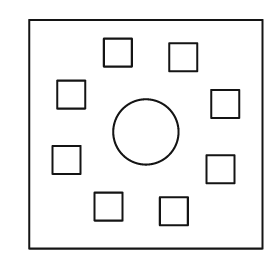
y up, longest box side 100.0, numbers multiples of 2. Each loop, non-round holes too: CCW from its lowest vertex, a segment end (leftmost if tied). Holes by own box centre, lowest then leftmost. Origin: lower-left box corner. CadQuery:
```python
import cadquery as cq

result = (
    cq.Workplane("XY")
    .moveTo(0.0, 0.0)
    .lineTo(100.0, 0.0)
    .lineTo(100.0, 98.0)
    .lineTo(0.0, 98.0)
    .close()
    .moveTo(56.0, 10.0)
    .lineTo(68.0, 10.0)
    .lineTo(68.0, 22.0)
    .lineTo(56.0, 22.0)
    .close()
    .moveTo(28.0, 12.0)
    .lineTo(40.0, 12.0)
    .lineTo(40.0, 24.0)
    .lineTo(28.0, 24.0)
    .close()
    .moveTo(76.0, 28.0)
    .lineTo(88.0, 28.0)
    .lineTo(88.0, 40.0)
    .lineTo(76.0, 40.0)
    .close()
    .moveTo(10.0, 32.0)
    .lineTo(22.0, 32.0)
    .lineTo(22.0, 44.0)
    .lineTo(10.0, 44.0)
    .close()
    .moveTo(50.0, 50.0)
    .circle(14.0)
    .moveTo(78.0, 56.0)
    .lineTo(90.0, 56.0)
    .lineTo(90.0, 68.0)
    .lineTo(78.0, 68.0)
    .close()
    .moveTo(12.0, 60.0)
    .lineTo(24.0, 60.0)
    .lineTo(24.0, 72.0)
    .lineTo(12.0, 72.0)
    .close()
    .moveTo(60.0, 76.0)
    .lineTo(72.0, 76.0)
    .lineTo(72.0, 88.0)
    .lineTo(60.0, 88.0)
    .close()
    .moveTo(32.0, 78.0)
    .lineTo(44.0, 78.0)
    .lineTo(44.0, 90.0)
    .lineTo(32.0, 90.0)
    .close()
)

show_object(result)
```